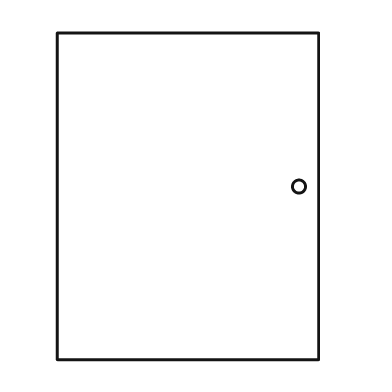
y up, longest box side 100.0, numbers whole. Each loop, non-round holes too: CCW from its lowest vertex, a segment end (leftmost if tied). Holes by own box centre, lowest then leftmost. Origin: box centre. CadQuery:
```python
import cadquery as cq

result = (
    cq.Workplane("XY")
    .moveTo(-40.0, -50.0)
    .lineTo(40.0, -50.0)
    .lineTo(40.0, 50.0)
    .lineTo(-40.0, 50.0)
    .close()
    .moveTo(34.0, 3.0)
    .circle(2.0)
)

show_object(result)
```